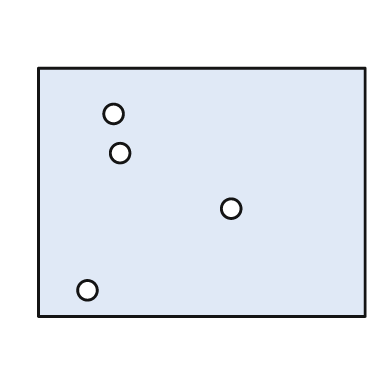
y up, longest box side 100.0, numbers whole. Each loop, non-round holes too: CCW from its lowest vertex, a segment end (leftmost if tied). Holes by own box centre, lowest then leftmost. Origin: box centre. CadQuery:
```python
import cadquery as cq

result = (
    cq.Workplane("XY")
    .moveTo(-50.0, -38.0)
    .lineTo(50.0, -38.0)
    .lineTo(50.0, 38.0)
    .lineTo(-50.0, 38.0)
    .close()
    .moveTo(-35.0, -30.0)
    .circle(3.0)
    .moveTo(9.0, -5.0)
    .circle(3.0)
    .moveTo(-25.0, 12.0)
    .circle(3.0)
    .moveTo(-27.0, 24.0)
    .circle(3.0)
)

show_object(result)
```